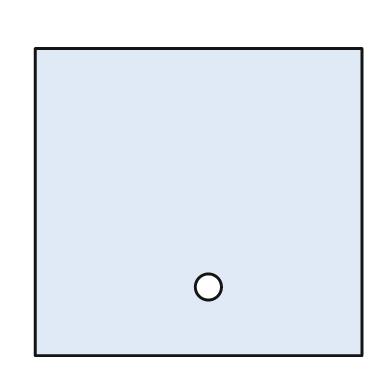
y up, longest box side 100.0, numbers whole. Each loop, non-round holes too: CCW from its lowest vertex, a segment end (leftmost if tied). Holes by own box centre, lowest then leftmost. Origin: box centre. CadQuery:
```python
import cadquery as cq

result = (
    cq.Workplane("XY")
    .moveTo(-50.0, -47.0)
    .lineTo(50.0, -47.0)
    .lineTo(50.0, 47.0)
    .lineTo(-50.0, 47.0)
    .close()
    .moveTo(3.0, -26.0)
    .circle(4.0)
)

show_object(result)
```